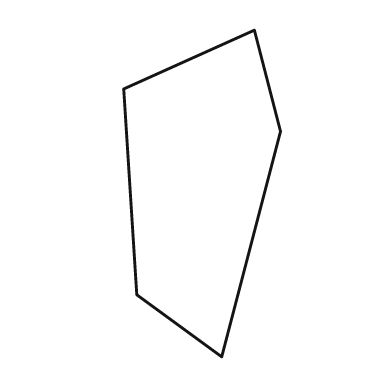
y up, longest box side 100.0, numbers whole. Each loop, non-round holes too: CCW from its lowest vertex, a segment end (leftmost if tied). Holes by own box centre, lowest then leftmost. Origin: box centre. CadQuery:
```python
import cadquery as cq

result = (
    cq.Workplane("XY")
    .moveTo(6.0, -50.0)
    .lineTo(24.0, 19.0)
    .lineTo(16.0, 50.0)
    .lineTo(-24.0, 32.0)
    .lineTo(-20.0, -31.0)
    .close()
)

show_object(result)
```